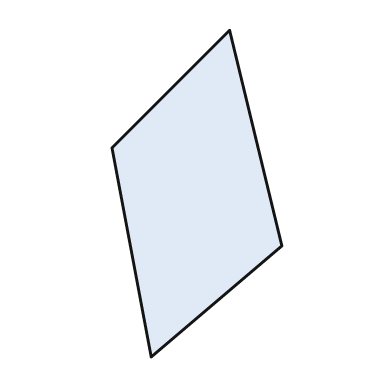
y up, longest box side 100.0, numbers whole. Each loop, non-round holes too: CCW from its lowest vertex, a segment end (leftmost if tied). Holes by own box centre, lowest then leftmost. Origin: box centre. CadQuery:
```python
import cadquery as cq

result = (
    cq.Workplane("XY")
    .moveTo(-14.0, -50.0)
    .lineTo(26.0, -16.0)
    .lineTo(10.0, 50.0)
    .lineTo(-26.0, 14.0)
    .close()
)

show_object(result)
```